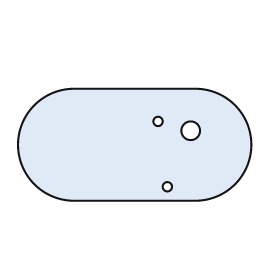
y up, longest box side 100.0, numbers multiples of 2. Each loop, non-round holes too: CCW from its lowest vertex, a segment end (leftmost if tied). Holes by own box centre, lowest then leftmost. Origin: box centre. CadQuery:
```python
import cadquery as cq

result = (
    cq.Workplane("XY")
    .moveTo(-26.0, -24.0)
    .lineTo(26.0, -24.0)
    .threePointArc((50.0, 0.0), (26.0, 24.0))
    .lineTo(-26.0, 24.0)
    .threePointArc((-50.0, 0.0), (-26.0, -24.0))
    .close()
    .moveTo(14.0, -18.0)
    .circle(2.0)
    .moveTo(24.0, 6.0)
    .circle(4.0)
    .moveTo(10.0, 10.0)
    .circle(2.0)
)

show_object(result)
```